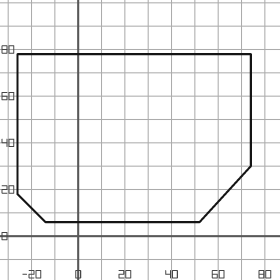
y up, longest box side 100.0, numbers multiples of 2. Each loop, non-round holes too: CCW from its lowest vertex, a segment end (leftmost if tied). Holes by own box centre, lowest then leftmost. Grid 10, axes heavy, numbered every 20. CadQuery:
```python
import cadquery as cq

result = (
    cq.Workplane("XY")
    .moveTo(-14.0, 6.0)
    .lineTo(52.0, 6.0)
    .lineTo(74.0, 30.0)
    .lineTo(74.0, 78.0)
    .lineTo(-26.0, 78.0)
    .lineTo(-26.0, 18.0)
    .close()
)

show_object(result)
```